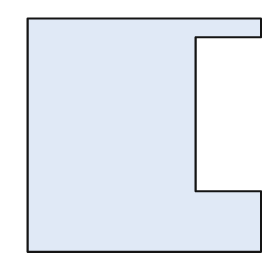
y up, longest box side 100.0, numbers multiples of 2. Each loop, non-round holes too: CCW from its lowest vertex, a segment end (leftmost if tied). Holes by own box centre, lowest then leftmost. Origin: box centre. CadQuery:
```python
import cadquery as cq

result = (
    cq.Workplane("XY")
    .moveTo(-50.0, -50.0)
    .lineTo(50.0, -50.0)
    .lineTo(50.0, -24.0)
    .lineTo(22.0, -24.0)
    .lineTo(22.0, 42.0)
    .lineTo(50.0, 42.0)
    .lineTo(50.0, 50.0)
    .lineTo(-50.0, 50.0)
    .close()
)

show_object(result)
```